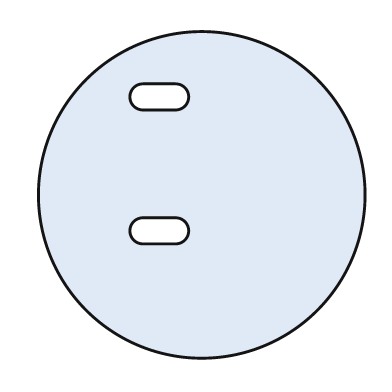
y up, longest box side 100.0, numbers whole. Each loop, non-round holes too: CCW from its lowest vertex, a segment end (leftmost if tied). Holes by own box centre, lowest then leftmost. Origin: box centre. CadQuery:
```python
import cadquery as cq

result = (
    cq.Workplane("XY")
    .moveTo(0.0, 0.0)
    .circle(50.0)
    .moveTo(-18.0, -15.0)
    .lineTo(-8.0, -15.0)
    .threePointArc((-4.0, -11.0), (-8.0, -7.0))
    .lineTo(-18.0, -7.0)
    .threePointArc((-22.0, -11.0), (-18.0, -15.0))
    .close()
    .moveTo(-18.0, 26.0)
    .lineTo(-8.0, 26.0)
    .threePointArc((-4.0, 30.0), (-8.0, 34.0))
    .lineTo(-18.0, 34.0)
    .threePointArc((-22.0, 30.0), (-18.0, 26.0))
    .close()
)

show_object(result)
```